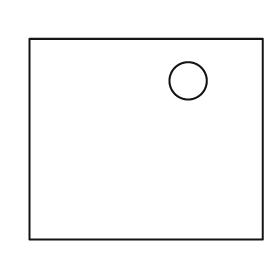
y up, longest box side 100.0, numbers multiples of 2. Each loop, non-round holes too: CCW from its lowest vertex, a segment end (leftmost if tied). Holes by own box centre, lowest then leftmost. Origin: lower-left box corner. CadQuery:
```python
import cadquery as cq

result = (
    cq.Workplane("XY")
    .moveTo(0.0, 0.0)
    .lineTo(100.0, 0.0)
    .lineTo(100.0, 86.0)
    .lineTo(0.0, 86.0)
    .close()
    .moveTo(68.0, 68.0)
    .circle(8.0)
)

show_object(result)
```